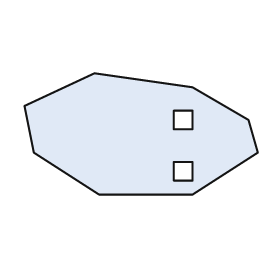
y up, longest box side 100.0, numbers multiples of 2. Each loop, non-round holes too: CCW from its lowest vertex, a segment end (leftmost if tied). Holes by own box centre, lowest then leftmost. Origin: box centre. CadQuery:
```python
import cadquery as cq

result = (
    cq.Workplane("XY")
    .moveTo(-18.0, -26.0)
    .lineTo(22.0, -26.0)
    .lineTo(50.0, -8.0)
    .lineTo(46.0, 6.0)
    .lineTo(22.0, 20.0)
    .lineTo(-20.0, 26.0)
    .lineTo(-50.0, 12.0)
    .lineTo(-46.0, -8.0)
    .close()
    .moveTo(14.0, -20.0)
    .lineTo(22.0, -20.0)
    .lineTo(22.0, -12.0)
    .lineTo(14.0, -12.0)
    .close()
    .moveTo(14.0, 2.0)
    .lineTo(22.0, 2.0)
    .lineTo(22.0, 10.0)
    .lineTo(14.0, 10.0)
    .close()
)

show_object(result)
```